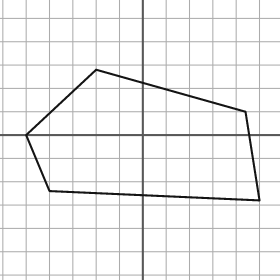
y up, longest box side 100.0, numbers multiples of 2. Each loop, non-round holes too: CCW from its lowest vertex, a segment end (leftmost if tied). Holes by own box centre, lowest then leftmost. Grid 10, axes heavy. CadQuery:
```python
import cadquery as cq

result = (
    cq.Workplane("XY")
    .moveTo(50.0, -28.0)
    .lineTo(44.0, 10.0)
    .lineTo(-20.0, 28.0)
    .lineTo(-50.0, 0.0)
    .lineTo(-40.0, -24.0)
    .close()
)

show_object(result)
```